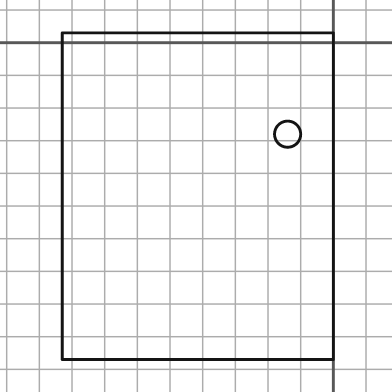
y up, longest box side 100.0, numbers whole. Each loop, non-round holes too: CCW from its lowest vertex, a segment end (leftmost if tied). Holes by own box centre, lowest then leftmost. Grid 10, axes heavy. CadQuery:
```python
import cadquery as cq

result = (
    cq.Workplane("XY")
    .moveTo(-83.0, -97.0)
    .lineTo(0.0, -97.0)
    .lineTo(0.0, 3.0)
    .lineTo(-83.0, 3.0)
    .close()
    .moveTo(-14.0, -28.0)
    .circle(4.0)
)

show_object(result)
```